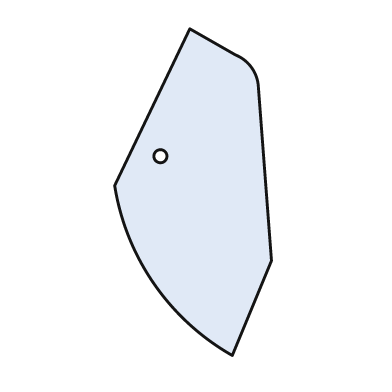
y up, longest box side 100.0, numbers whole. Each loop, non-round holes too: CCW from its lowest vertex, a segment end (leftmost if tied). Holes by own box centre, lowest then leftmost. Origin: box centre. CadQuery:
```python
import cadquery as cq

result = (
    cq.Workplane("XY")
    .moveTo(12.0, -50.0)
    .lineTo(24.0, -21.0)
    .lineTo(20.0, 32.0)
    .threePointArc((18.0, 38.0), (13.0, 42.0))
    .lineTo(-1.0, 50.0)
    .lineTo(-24.0, 2.0)
    .threePointArc((-12.0, -28.0), (12.0, -50.0))
    .close()
    .moveTo(-10.0, 11.0)
    .circle(2.0)
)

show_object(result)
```